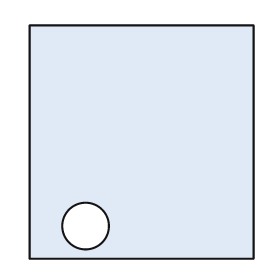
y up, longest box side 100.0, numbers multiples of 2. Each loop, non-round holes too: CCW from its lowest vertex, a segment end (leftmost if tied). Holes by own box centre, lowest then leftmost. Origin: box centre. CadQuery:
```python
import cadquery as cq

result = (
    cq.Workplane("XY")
    .moveTo(-48.0, -50.0)
    .lineTo(48.0, -50.0)
    .lineTo(48.0, 50.0)
    .lineTo(-48.0, 50.0)
    .close()
    .moveTo(-24.0, -36.0)
    .circle(10.0)
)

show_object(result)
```